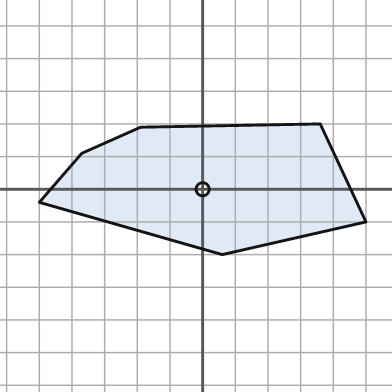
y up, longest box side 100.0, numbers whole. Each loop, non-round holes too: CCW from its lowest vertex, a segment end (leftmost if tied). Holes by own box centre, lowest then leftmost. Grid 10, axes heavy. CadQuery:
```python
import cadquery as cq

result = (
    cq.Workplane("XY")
    .moveTo(6.0, -20.0)
    .lineTo(50.0, -10.0)
    .lineTo(36.0, 20.0)
    .lineTo(-19.0, 19.0)
    .lineTo(-37.0, 11.0)
    .lineTo(-50.0, -4.0)
    .close()
    .moveTo(0.0, 0.0)
    .circle(2.0)
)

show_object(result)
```